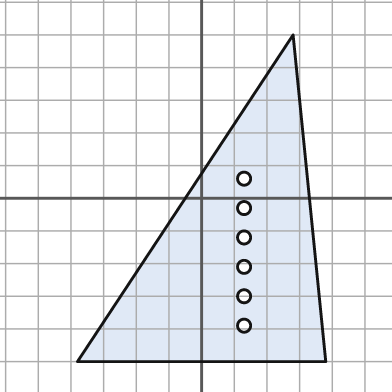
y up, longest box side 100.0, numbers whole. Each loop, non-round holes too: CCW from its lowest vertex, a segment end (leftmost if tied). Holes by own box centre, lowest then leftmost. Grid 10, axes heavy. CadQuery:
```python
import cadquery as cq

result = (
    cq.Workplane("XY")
    .moveTo(-38.0, -50.0)
    .lineTo(38.0, -50.0)
    .lineTo(28.0, 50.0)
    .close()
    .moveTo(13.0, -39.0)
    .circle(2.0)
    .moveTo(13.0, -30.0)
    .circle(2.0)
    .moveTo(13.0, -21.0)
    .circle(2.0)
    .moveTo(13.0, -12.0)
    .circle(2.0)
    .moveTo(13.0, -3.0)
    .circle(2.0)
    .moveTo(13.0, 6.0)
    .circle(2.0)
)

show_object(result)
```